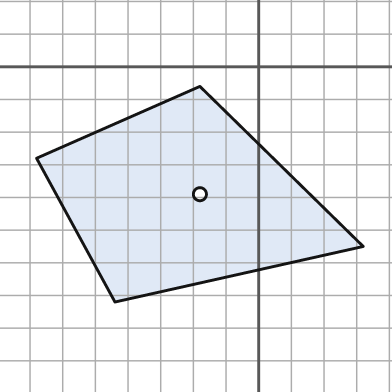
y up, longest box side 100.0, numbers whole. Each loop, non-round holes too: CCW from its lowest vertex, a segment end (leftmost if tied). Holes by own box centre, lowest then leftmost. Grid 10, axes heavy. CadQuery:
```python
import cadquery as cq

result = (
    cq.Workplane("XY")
    .moveTo(-44.0, -72.0)
    .lineTo(32.0, -55.0)
    .lineTo(-18.0, -6.0)
    .lineTo(-68.0, -28.0)
    .close()
    .moveTo(-18.0, -39.0)
    .circle(2.0)
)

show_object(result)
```